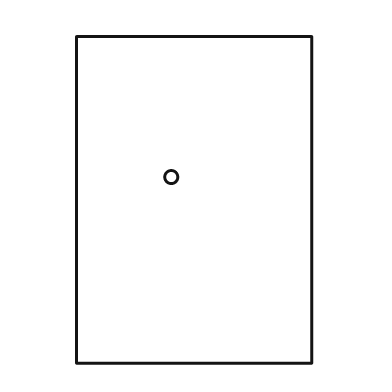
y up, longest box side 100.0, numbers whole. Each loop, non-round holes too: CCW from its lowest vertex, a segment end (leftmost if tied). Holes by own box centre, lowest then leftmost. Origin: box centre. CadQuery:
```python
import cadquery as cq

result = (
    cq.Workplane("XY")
    .moveTo(-36.0, -50.0)
    .lineTo(36.0, -50.0)
    .lineTo(36.0, 50.0)
    .lineTo(-36.0, 50.0)
    .close()
    .moveTo(-7.0, 7.0)
    .circle(2.0)
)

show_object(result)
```